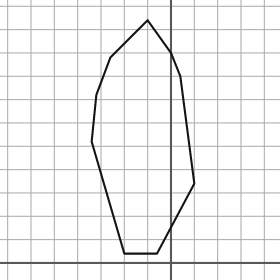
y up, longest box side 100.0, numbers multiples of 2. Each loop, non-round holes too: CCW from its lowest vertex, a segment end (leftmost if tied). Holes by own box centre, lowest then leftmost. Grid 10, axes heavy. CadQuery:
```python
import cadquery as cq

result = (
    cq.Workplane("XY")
    .moveTo(-20.0, 4.0)
    .lineTo(-6.0, 4.0)
    .lineTo(10.0, 34.0)
    .lineTo(4.0, 80.0)
    .lineTo(0.0, 90.0)
    .lineTo(-10.0, 104.0)
    .lineTo(-26.0, 88.0)
    .lineTo(-32.0, 72.0)
    .lineTo(-34.0, 52.0)
    .close()
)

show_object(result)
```